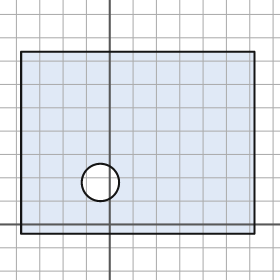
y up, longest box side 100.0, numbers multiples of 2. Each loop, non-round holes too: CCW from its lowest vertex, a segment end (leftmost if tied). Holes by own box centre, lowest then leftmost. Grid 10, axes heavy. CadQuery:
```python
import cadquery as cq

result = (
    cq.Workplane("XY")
    .moveTo(-38.0, -4.0)
    .lineTo(62.0, -4.0)
    .lineTo(62.0, 74.0)
    .lineTo(-38.0, 74.0)
    .close()
    .moveTo(-4.0, 18.0)
    .circle(8.0)
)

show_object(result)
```